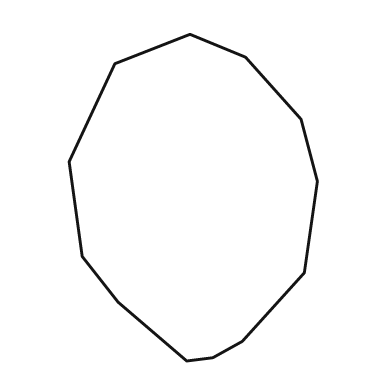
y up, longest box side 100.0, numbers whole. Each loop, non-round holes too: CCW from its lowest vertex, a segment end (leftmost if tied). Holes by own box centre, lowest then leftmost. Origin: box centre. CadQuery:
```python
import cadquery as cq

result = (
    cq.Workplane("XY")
    .moveTo(-2.0, -50.0)
    .lineTo(6.0, -49.0)
    .lineTo(15.0, -44.0)
    .lineTo(34.0, -23.0)
    .lineTo(38.0, 5.0)
    .lineTo(33.0, 24.0)
    .lineTo(16.0, 43.0)
    .lineTo(-1.0, 50.0)
    .lineTo(-24.0, 41.0)
    .lineTo(-38.0, 11.0)
    .lineTo(-34.0, -18.0)
    .lineTo(-23.0, -32.0)
    .close()
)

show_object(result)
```